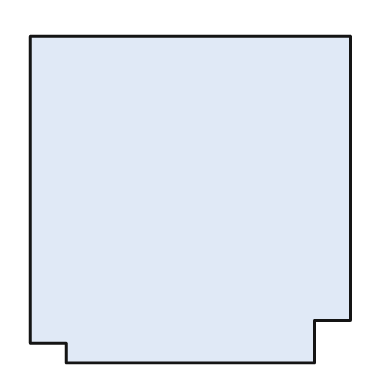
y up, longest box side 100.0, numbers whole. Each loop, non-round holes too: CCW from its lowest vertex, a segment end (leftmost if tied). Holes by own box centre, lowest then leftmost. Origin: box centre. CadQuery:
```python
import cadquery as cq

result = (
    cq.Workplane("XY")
    .moveTo(-38.0, -50.0)
    .lineTo(38.0, -50.0)
    .lineTo(38.0, -37.0)
    .lineTo(49.0, -37.0)
    .lineTo(49.0, 50.0)
    .lineTo(-49.0, 50.0)
    .lineTo(-49.0, -44.0)
    .lineTo(-38.0, -44.0)
    .close()
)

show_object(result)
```